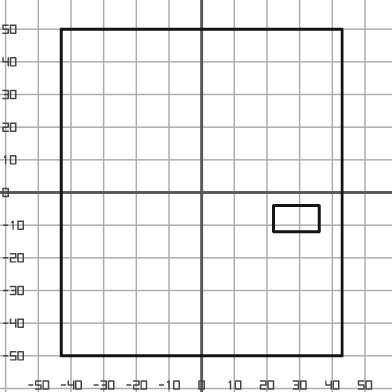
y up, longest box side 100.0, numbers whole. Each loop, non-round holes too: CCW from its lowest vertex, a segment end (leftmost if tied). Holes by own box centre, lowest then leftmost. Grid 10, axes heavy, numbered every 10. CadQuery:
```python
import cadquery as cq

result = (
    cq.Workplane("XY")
    .moveTo(-43.0, -50.0)
    .lineTo(43.0, -50.0)
    .lineTo(43.0, 50.0)
    .lineTo(-43.0, 50.0)
    .close()
    .moveTo(22.0, -12.0)
    .lineTo(36.0, -12.0)
    .lineTo(36.0, -4.0)
    .lineTo(22.0, -4.0)
    .close()
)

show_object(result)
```